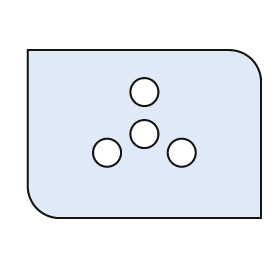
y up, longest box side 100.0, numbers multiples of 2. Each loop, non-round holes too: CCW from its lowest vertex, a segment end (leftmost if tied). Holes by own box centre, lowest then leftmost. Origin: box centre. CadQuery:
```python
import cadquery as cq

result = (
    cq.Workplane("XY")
    .moveTo(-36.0, -36.0)
    .lineTo(50.0, -36.0)
    .lineTo(50.0, 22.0)
    .threePointArc((46.0, 32.0), (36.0, 36.0))
    .lineTo(-50.0, 36.0)
    .lineTo(-50.0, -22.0)
    .threePointArc((-46.0, -32.0), (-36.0, -36.0))
    .close()
    .moveTo(-16.0, -8.0)
    .circle(6.0)
    .moveTo(16.0, -8.0)
    .circle(6.0)
    .moveTo(0.0, 0.0)
    .circle(6.0)
    .moveTo(0.0, 18.0)
    .circle(6.0)
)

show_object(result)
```